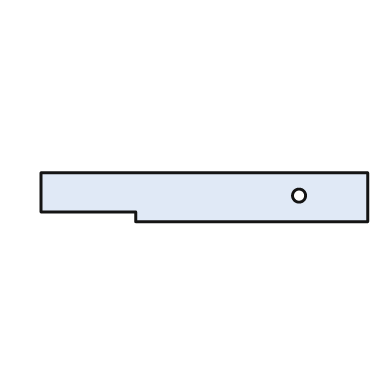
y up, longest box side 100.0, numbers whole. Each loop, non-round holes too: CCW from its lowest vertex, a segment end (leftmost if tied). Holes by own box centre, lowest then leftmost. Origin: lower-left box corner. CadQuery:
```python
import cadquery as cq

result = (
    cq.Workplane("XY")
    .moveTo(29.0, 0.0)
    .lineTo(100.0, 0.0)
    .lineTo(100.0, 15.0)
    .lineTo(0.0, 15.0)
    .lineTo(0.0, 3.0)
    .lineTo(29.0, 3.0)
    .close()
    .moveTo(79.0, 8.0)
    .circle(2.0)
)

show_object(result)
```